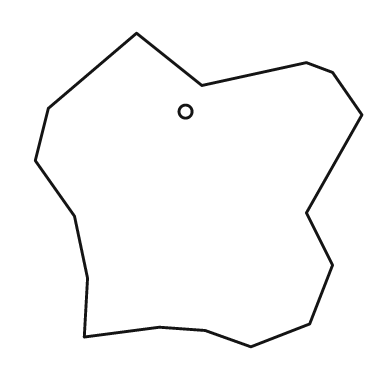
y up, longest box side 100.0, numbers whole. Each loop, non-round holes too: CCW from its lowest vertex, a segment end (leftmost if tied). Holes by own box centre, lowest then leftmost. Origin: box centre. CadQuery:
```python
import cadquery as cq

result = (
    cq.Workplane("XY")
    .moveTo(16.0, -48.0)
    .lineTo(34.0, -41.0)
    .lineTo(41.0, -23.0)
    .lineTo(33.0, -7.0)
    .lineTo(50.0, 23.0)
    .lineTo(41.0, 36.0)
    .lineTo(33.0, 39.0)
    .lineTo(1.0, 32.0)
    .lineTo(-19.0, 48.0)
    .lineTo(-46.0, 25.0)
    .lineTo(-50.0, 9.0)
    .lineTo(-38.0, -8.0)
    .lineTo(-34.0, -27.0)
    .lineTo(-35.0, -45.0)
    .lineTo(-12.0, -42.0)
    .lineTo(2.0, -43.0)
    .close()
    .moveTo(-4.0, 24.0)
    .circle(2.0)
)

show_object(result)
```